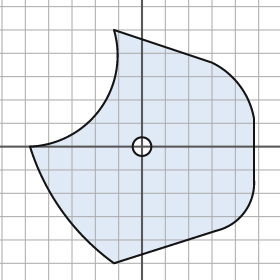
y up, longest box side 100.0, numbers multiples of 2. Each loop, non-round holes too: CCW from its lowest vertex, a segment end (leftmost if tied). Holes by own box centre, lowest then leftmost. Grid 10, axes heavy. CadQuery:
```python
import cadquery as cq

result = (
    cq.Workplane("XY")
    .moveTo(-12.0, -50.0)
    .lineTo(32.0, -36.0)
    .threePointArc((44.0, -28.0), (48.0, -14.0))
    .lineTo(48.0, 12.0)
    .threePointArc((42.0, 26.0), (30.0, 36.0))
    .lineTo(-12.0, 50.0)
    .threePointArc((-18.0, 16.0), (-48.0, 0.0))
    .threePointArc((-34.0, -28.0), (-12.0, -50.0))
    .close()
    .moveTo(0.0, 0.0)
    .circle(4.0)
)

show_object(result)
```